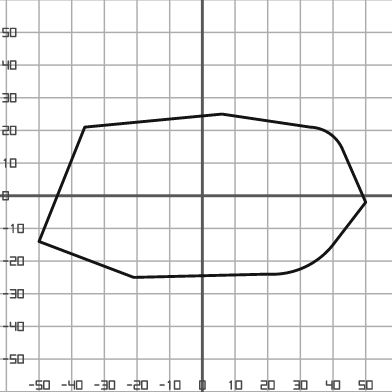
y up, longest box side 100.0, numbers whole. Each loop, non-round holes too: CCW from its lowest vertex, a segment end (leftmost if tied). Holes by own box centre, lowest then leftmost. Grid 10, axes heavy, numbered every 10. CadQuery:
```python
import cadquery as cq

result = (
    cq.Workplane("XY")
    .moveTo(-21.0, -25.0)
    .lineTo(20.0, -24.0)
    .threePointArc((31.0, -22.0), (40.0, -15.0))
    .lineTo(50.0, -2.0)
    .lineTo(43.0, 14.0)
    .threePointArc((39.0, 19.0), (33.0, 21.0))
    .lineTo(6.0, 25.0)
    .lineTo(-36.0, 21.0)
    .lineTo(-50.0, -14.0)
    .close()
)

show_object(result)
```